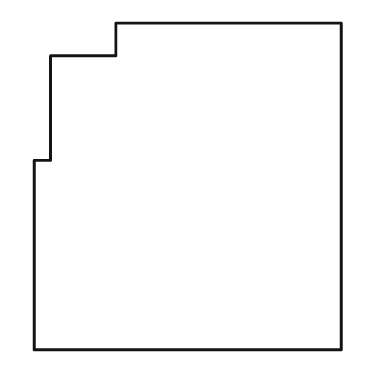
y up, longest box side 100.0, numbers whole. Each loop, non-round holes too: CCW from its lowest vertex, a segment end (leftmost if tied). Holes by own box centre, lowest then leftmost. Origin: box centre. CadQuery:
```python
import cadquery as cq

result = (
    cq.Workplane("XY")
    .moveTo(-47.0, -50.0)
    .lineTo(47.0, -50.0)
    .lineTo(47.0, 50.0)
    .lineTo(-22.0, 50.0)
    .lineTo(-22.0, 40.0)
    .lineTo(-42.0, 40.0)
    .lineTo(-42.0, 8.0)
    .lineTo(-47.0, 8.0)
    .close()
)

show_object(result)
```